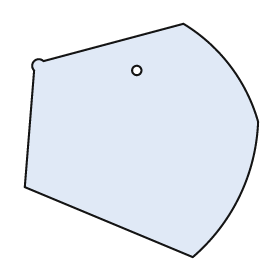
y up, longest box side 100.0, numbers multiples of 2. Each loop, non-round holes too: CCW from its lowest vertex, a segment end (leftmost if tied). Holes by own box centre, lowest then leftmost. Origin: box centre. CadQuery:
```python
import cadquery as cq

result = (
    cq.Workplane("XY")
    .moveTo(22.0, -50.0)
    .threePointArc((42.0, -24.0), (50.0, 8.0))
    .threePointArc((38.0, 32.0), (18.0, 50.0))
    .lineTo(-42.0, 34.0)
    .threePointArc((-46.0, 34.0), (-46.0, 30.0))
    .lineTo(-50.0, -20.0)
    .close()
    .moveTo(-2.0, 30.0)
    .circle(2.0)
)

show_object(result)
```